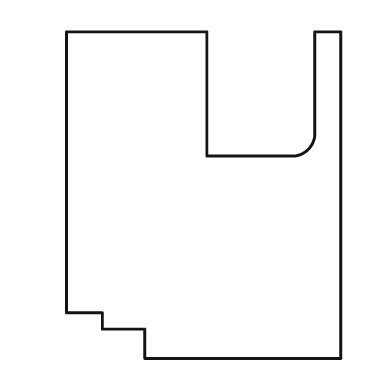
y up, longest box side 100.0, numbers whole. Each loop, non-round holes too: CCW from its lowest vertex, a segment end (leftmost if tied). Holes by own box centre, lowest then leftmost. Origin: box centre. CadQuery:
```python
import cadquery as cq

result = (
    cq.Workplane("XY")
    .moveTo(-18.0, -50.0)
    .lineTo(42.0, -50.0)
    .lineTo(42.0, 50.0)
    .lineTo(34.0, 50.0)
    .lineTo(34.0, 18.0)
    .threePointArc((32.0, 14.0), (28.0, 12.0))
    .lineTo(1.0, 12.0)
    .lineTo(1.0, 50.0)
    .lineTo(-42.0, 50.0)
    .lineTo(-42.0, -36.0)
    .lineTo(-31.0, -36.0)
    .lineTo(-31.0, -41.0)
    .lineTo(-18.0, -41.0)
    .close()
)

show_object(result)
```